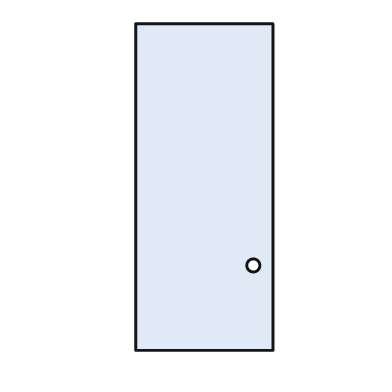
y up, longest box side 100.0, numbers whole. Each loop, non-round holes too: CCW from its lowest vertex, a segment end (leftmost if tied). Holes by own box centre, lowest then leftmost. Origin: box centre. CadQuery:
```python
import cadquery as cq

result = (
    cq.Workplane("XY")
    .moveTo(-21.0, -50.0)
    .lineTo(21.0, -50.0)
    .lineTo(21.0, 50.0)
    .lineTo(-21.0, 50.0)
    .close()
    .moveTo(15.0, -24.0)
    .circle(2.0)
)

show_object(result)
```